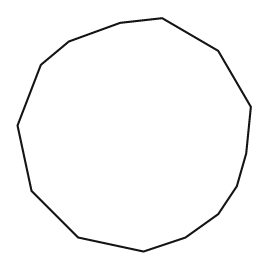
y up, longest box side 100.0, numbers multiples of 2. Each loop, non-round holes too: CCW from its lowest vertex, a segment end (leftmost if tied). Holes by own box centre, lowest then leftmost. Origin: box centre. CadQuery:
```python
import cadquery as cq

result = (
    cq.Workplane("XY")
    .moveTo(4.0, -50.0)
    .lineTo(22.0, -44.0)
    .lineTo(36.0, -34.0)
    .lineTo(44.0, -22.0)
    .lineTo(48.0, -8.0)
    .lineTo(50.0, 12.0)
    .lineTo(36.0, 36.0)
    .lineTo(12.0, 50.0)
    .lineTo(-6.0, 48.0)
    .lineTo(-28.0, 40.0)
    .lineTo(-40.0, 30.0)
    .lineTo(-50.0, 4.0)
    .lineTo(-44.0, -24.0)
    .lineTo(-24.0, -44.0)
    .close()
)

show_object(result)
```